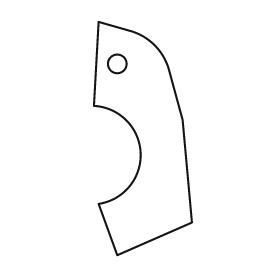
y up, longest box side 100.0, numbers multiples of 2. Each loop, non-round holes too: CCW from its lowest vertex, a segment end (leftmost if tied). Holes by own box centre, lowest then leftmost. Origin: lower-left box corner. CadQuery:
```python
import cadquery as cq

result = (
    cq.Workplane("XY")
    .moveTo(10.0, 0.0)
    .lineTo(42.0, 14.0)
    .lineTo(38.0, 58.0)
    .lineTo(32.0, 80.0)
    .threePointArc((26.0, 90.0), (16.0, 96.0))
    .lineTo(2.0, 100.0)
    .lineTo(0.0, 64.0)
    .threePointArc((20.0, 44.0), (2.0, 22.0))
    .close()
    .moveTo(10.0, 82.0)
    .circle(4.0)
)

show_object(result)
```